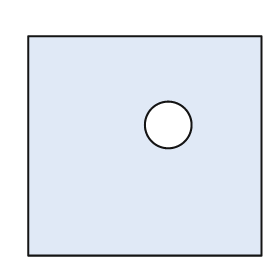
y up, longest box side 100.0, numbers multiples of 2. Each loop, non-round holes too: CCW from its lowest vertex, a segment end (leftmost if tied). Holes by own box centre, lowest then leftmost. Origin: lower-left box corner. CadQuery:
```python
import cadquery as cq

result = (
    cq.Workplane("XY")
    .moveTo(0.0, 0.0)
    .lineTo(100.0, 0.0)
    .lineTo(100.0, 94.0)
    .lineTo(0.0, 94.0)
    .close()
    .moveTo(60.0, 56.0)
    .circle(10.0)
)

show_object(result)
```